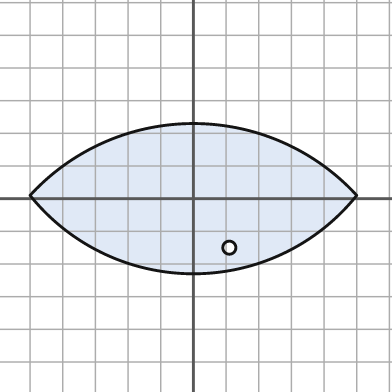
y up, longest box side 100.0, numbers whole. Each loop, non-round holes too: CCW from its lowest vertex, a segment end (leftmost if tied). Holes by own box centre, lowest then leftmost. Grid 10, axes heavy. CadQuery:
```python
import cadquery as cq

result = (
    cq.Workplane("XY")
    .moveTo(-50.0, 1.0)
    .threePointArc((0.0, -23.0), (50.0, 1.0))
    .threePointArc((0.0, 23.0), (-50.0, 1.0))
    .close()
    .moveTo(11.0, -15.0)
    .circle(2.0)
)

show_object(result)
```